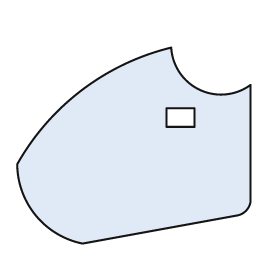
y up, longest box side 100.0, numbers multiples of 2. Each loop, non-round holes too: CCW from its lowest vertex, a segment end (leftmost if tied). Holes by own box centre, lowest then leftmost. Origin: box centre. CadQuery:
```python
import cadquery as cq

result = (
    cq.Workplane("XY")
    .moveTo(-22.0, -42.0)
    .lineTo(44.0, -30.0)
    .threePointArc((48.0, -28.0), (50.0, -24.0))
    .lineTo(50.0, 26.0)
    .threePointArc((28.0, 24.0), (16.0, 42.0))
    .threePointArc((-22.0, 24.0), (-50.0, -8.0))
    .threePointArc((-42.0, -30.0), (-22.0, -42.0))
    .close()
    .moveTo(14.0, 8.0)
    .lineTo(26.0, 8.0)
    .lineTo(26.0, 16.0)
    .lineTo(14.0, 16.0)
    .close()
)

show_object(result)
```